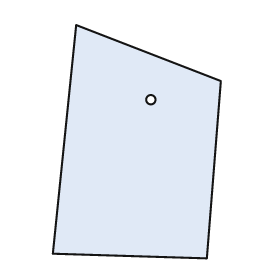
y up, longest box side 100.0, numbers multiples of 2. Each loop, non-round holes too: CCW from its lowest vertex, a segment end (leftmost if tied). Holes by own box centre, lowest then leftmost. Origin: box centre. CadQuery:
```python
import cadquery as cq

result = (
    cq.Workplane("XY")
    .moveTo(30.0, -50.0)
    .lineTo(36.0, 26.0)
    .lineTo(-26.0, 50.0)
    .lineTo(-36.0, -48.0)
    .close()
    .moveTo(6.0, 18.0)
    .circle(2.0)
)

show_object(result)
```